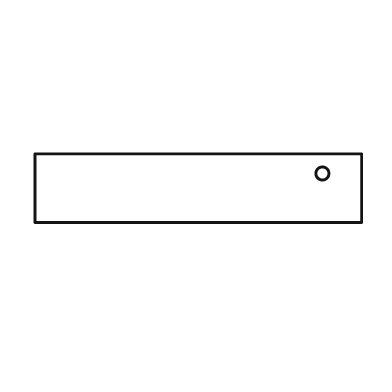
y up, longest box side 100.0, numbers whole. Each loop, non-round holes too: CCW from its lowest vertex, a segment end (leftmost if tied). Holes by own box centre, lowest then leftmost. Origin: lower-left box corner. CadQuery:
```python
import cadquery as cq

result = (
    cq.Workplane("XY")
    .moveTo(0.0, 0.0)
    .lineTo(100.0, 0.0)
    .lineTo(100.0, 21.0)
    .lineTo(0.0, 21.0)
    .close()
    .moveTo(88.0, 15.0)
    .circle(2.0)
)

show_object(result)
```